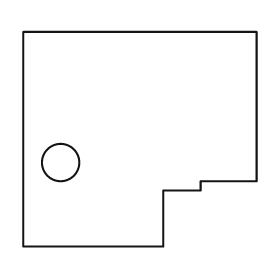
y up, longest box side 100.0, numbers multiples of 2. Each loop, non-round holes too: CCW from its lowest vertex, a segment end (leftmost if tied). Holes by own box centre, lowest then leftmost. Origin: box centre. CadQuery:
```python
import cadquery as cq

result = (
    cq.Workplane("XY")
    .moveTo(-50.0, -46.0)
    .lineTo(10.0, -46.0)
    .lineTo(10.0, -22.0)
    .lineTo(26.0, -22.0)
    .lineTo(26.0, -18.0)
    .lineTo(50.0, -18.0)
    .lineTo(50.0, 46.0)
    .lineTo(-50.0, 46.0)
    .close()
    .moveTo(-34.0, -10.0)
    .circle(8.0)
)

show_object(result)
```